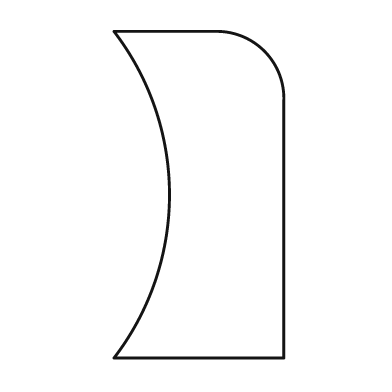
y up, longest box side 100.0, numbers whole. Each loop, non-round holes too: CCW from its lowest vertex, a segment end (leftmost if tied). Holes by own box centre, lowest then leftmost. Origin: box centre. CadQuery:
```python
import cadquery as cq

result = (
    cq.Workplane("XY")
    .moveTo(-26.0, -50.0)
    .lineTo(26.0, -50.0)
    .lineTo(26.0, 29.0)
    .threePointArc((20.0, 44.0), (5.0, 50.0))
    .lineTo(-26.0, 50.0)
    .threePointArc((-9.0, 0.0), (-26.0, -50.0))
    .close()
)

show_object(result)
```